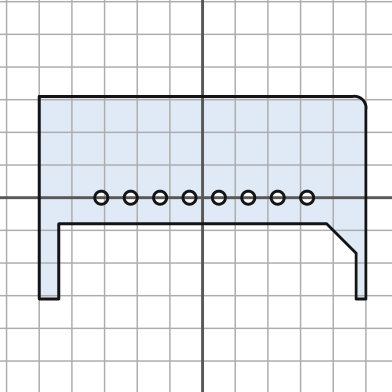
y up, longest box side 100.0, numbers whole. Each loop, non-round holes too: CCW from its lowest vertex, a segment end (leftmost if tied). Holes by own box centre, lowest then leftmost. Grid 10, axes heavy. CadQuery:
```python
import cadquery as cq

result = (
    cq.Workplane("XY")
    .moveTo(-50.0, -31.0)
    .lineTo(-44.0, -31.0)
    .lineTo(-44.0, -8.0)
    .lineTo(38.0, -8.0)
    .lineTo(47.0, -17.0)
    .lineTo(47.0, -31.0)
    .lineTo(50.0, -31.0)
    .lineTo(50.0, 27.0)
    .threePointArc((49.0, 30.0), (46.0, 31.0))
    .lineTo(-50.0, 31.0)
    .close()
    .moveTo(-31.0, 0.0)
    .circle(2.0)
    .moveTo(-22.0, 0.0)
    .circle(2.0)
    .moveTo(-13.0, 0.0)
    .circle(2.0)
    .moveTo(-4.0, 0.0)
    .circle(2.0)
    .moveTo(5.0, 0.0)
    .circle(2.0)
    .moveTo(14.0, 0.0)
    .circle(2.0)
    .moveTo(23.0, 0.0)
    .circle(2.0)
    .moveTo(32.0, 0.0)
    .circle(2.0)
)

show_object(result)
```